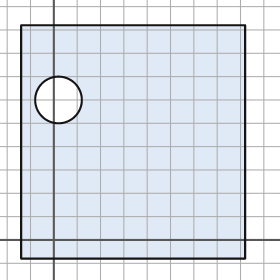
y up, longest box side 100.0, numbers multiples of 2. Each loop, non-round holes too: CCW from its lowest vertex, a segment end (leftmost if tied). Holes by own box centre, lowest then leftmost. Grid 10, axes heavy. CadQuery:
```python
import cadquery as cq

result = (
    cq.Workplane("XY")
    .moveTo(-14.0, -8.0)
    .lineTo(82.0, -8.0)
    .lineTo(82.0, 92.0)
    .lineTo(-14.0, 92.0)
    .close()
    .moveTo(2.0, 60.0)
    .circle(10.0)
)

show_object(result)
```